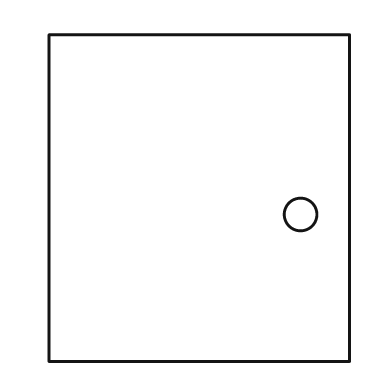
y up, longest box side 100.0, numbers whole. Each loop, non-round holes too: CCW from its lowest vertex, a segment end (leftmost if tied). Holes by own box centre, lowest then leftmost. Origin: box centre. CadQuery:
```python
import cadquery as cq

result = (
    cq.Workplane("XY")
    .moveTo(-46.0, -50.0)
    .lineTo(46.0, -50.0)
    .lineTo(46.0, 50.0)
    .lineTo(-46.0, 50.0)
    .close()
    .moveTo(31.0, -5.0)
    .circle(5.0)
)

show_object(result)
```